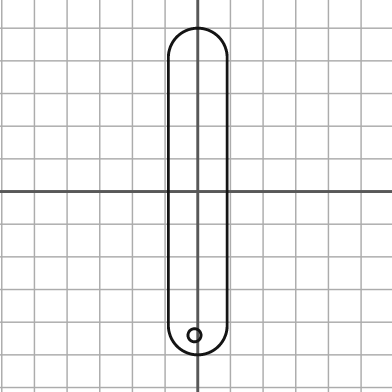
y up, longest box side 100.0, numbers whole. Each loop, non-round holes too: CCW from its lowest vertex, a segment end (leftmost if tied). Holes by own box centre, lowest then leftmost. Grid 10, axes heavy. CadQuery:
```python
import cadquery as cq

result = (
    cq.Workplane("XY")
    .moveTo(-9.0, -41.0)
    .threePointArc((0.0, -50.0), (9.0, -41.0))
    .lineTo(9.0, 41.0)
    .threePointArc((0.0, 50.0), (-9.0, 41.0))
    .close()
    .moveTo(-1.0, -44.0)
    .circle(2.0)
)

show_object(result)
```